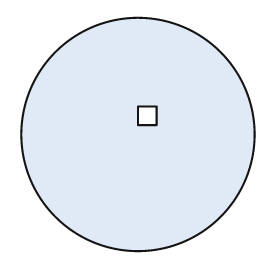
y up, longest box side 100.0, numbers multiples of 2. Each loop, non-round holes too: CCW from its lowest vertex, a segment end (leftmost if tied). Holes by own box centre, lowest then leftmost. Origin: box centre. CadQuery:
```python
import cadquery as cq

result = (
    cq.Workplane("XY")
    .moveTo(0.0, 0.0)
    .circle(50.0)
    .moveTo(0.0, 4.0)
    .lineTo(8.0, 4.0)
    .lineTo(8.0, 12.0)
    .lineTo(0.0, 12.0)
    .close()
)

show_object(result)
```